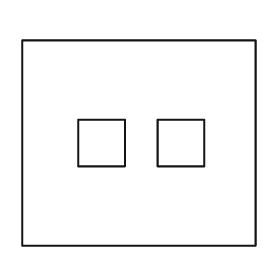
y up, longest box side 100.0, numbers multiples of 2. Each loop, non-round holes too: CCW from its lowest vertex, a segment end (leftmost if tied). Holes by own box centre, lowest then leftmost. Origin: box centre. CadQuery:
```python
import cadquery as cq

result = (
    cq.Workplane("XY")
    .moveTo(-50.0, -44.0)
    .lineTo(50.0, -44.0)
    .lineTo(50.0, 44.0)
    .lineTo(-50.0, 44.0)
    .close()
    .moveTo(-26.0, -10.0)
    .lineTo(-6.0, -10.0)
    .lineTo(-6.0, 10.0)
    .lineTo(-26.0, 10.0)
    .close()
    .moveTo(8.0, -10.0)
    .lineTo(28.0, -10.0)
    .lineTo(28.0, 10.0)
    .lineTo(8.0, 10.0)
    .close()
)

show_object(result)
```